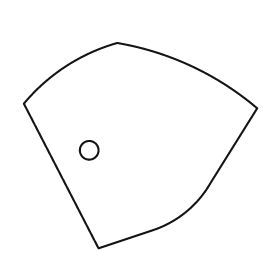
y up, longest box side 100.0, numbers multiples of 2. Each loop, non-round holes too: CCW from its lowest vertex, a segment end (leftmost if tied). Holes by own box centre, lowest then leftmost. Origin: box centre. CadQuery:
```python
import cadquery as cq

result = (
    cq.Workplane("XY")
    .moveTo(-18.0, -44.0)
    .lineTo(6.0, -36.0)
    .threePointArc((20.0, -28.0), (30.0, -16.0))
    .lineTo(50.0, 16.0)
    .threePointArc((22.0, 34.0), (-10.0, 44.0))
    .threePointArc((-32.0, 34.0), (-50.0, 18.0))
    .close()
    .moveTo(-22.0, -2.0)
    .circle(4.0)
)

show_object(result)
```